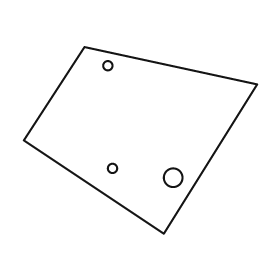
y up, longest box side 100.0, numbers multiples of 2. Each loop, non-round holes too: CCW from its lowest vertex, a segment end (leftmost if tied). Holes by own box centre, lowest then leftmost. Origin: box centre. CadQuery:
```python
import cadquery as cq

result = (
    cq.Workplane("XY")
    .moveTo(10.0, -40.0)
    .lineTo(50.0, 24.0)
    .lineTo(-24.0, 40.0)
    .lineTo(-50.0, 0.0)
    .close()
    .moveTo(14.0, -16.0)
    .circle(4.0)
    .moveTo(-12.0, -12.0)
    .circle(2.0)
    .moveTo(-14.0, 32.0)
    .circle(2.0)
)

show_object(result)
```